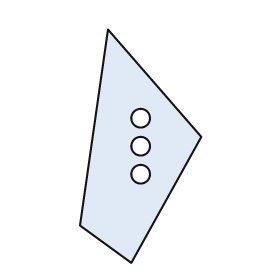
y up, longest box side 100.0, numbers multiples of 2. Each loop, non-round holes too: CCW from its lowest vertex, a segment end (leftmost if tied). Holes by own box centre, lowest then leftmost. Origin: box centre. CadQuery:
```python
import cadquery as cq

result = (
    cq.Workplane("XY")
    .moveTo(-4.0, -50.0)
    .lineTo(26.0, 4.0)
    .lineTo(-14.0, 50.0)
    .lineTo(-26.0, -34.0)
    .close()
    .moveTo(0.0, -12.0)
    .circle(4.0)
    .moveTo(0.0, 0.0)
    .circle(4.0)
    .moveTo(0.0, 12.0)
    .circle(4.0)
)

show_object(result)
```